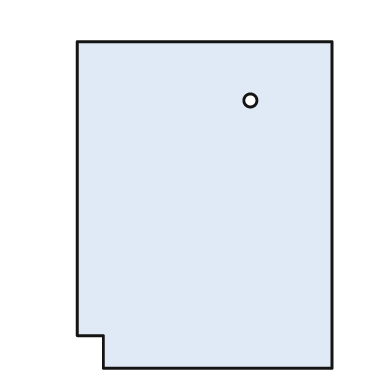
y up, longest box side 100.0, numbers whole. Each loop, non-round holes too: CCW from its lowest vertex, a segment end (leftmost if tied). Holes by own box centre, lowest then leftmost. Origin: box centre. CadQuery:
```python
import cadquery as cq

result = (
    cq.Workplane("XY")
    .moveTo(-31.0, -50.0)
    .lineTo(39.0, -50.0)
    .lineTo(39.0, 50.0)
    .lineTo(-39.0, 50.0)
    .lineTo(-39.0, -40.0)
    .lineTo(-31.0, -40.0)
    .close()
    .moveTo(14.0, 32.0)
    .circle(2.0)
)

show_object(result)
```